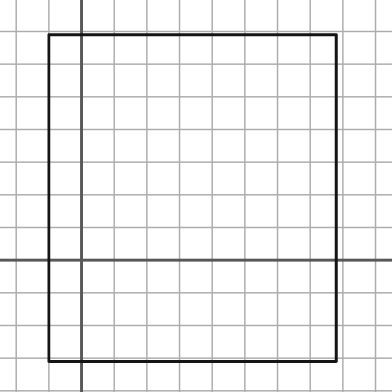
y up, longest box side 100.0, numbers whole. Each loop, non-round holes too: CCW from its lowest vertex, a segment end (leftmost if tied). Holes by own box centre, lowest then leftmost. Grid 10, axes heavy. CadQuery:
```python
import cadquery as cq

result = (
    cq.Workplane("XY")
    .moveTo(-10.0, -31.0)
    .lineTo(78.0, -31.0)
    .lineTo(78.0, 69.0)
    .lineTo(-10.0, 69.0)
    .close()
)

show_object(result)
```